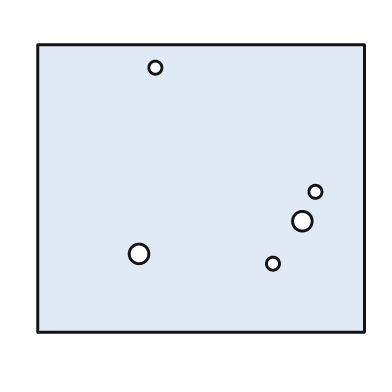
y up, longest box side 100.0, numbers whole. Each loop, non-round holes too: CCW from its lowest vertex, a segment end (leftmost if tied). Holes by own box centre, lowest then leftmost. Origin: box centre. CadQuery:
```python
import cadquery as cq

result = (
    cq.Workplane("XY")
    .moveTo(-50.0, -44.0)
    .lineTo(50.0, -44.0)
    .lineTo(50.0, 44.0)
    .lineTo(-50.0, 44.0)
    .close()
    .moveTo(22.0, -23.0)
    .circle(2.0)
    .moveTo(-19.0, -20.0)
    .circle(3.0)
    .moveTo(31.0, -10.0)
    .circle(3.0)
    .moveTo(35.0, -1.0)
    .circle(2.0)
    .moveTo(-14.0, 37.0)
    .circle(2.0)
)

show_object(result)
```